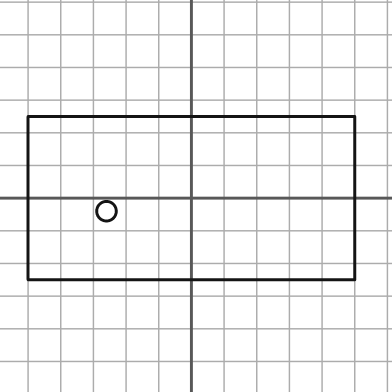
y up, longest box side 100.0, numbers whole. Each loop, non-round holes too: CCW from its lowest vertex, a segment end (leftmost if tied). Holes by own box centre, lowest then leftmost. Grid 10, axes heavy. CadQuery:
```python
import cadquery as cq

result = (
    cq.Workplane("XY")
    .moveTo(-50.0, -25.0)
    .lineTo(50.0, -25.0)
    .lineTo(50.0, 25.0)
    .lineTo(-50.0, 25.0)
    .close()
    .moveTo(-26.0, -4.0)
    .circle(3.0)
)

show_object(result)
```